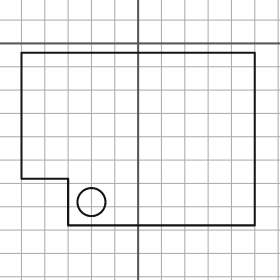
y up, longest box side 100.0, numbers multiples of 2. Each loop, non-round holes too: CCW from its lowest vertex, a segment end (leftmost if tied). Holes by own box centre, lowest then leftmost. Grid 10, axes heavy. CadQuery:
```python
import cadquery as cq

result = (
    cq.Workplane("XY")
    .moveTo(-30.0, -78.0)
    .lineTo(50.0, -78.0)
    .lineTo(50.0, -4.0)
    .lineTo(-50.0, -4.0)
    .lineTo(-50.0, -58.0)
    .lineTo(-30.0, -58.0)
    .close()
    .moveTo(-20.0, -68.0)
    .circle(6.0)
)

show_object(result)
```